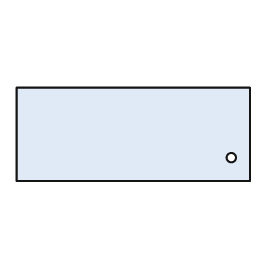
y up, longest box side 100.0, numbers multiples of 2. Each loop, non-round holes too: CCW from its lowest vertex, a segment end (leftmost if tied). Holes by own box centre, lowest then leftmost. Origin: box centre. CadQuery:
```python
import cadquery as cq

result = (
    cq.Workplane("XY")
    .moveTo(-50.0, -20.0)
    .lineTo(50.0, -20.0)
    .lineTo(50.0, 20.0)
    .lineTo(-50.0, 20.0)
    .close()
    .moveTo(42.0, -10.0)
    .circle(2.0)
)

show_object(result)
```